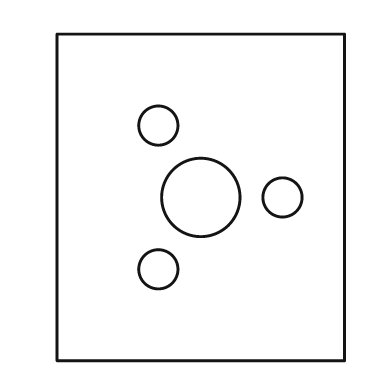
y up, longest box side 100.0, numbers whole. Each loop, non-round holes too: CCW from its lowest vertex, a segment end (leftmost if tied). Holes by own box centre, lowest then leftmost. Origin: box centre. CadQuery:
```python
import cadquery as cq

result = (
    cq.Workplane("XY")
    .moveTo(-44.0, -50.0)
    .lineTo(44.0, -50.0)
    .lineTo(44.0, 50.0)
    .lineTo(-44.0, 50.0)
    .close()
    .moveTo(-13.0, -22.0)
    .circle(6.0)
    .moveTo(0.0, 0.0)
    .circle(12.0)
    .moveTo(25.0, 0.0)
    .circle(6.0)
    .moveTo(-13.0, 22.0)
    .circle(6.0)
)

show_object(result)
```